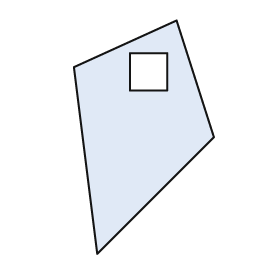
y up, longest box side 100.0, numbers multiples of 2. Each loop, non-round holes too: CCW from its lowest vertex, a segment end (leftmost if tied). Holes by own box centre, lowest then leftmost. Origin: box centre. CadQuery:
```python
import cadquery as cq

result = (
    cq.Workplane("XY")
    .moveTo(-20.0, -50.0)
    .lineTo(30.0, 0.0)
    .lineTo(14.0, 50.0)
    .lineTo(-30.0, 30.0)
    .close()
    .moveTo(-6.0, 20.0)
    .lineTo(10.0, 20.0)
    .lineTo(10.0, 36.0)
    .lineTo(-6.0, 36.0)
    .close()
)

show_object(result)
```